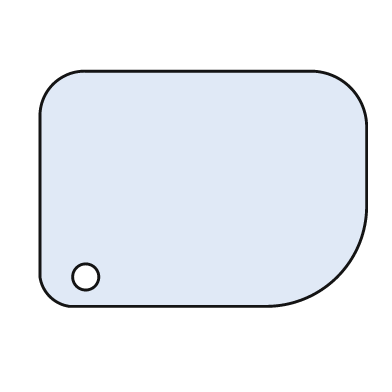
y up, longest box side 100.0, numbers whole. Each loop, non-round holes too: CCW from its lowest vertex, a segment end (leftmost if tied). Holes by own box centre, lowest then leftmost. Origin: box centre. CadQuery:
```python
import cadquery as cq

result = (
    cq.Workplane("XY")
    .moveTo(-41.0, -36.0)
    .lineTo(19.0, -36.0)
    .threePointArc((41.0, -27.0), (50.0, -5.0))
    .lineTo(50.0, 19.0)
    .threePointArc((45.0, 31.0), (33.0, 36.0))
    .lineTo(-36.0, 36.0)
    .threePointArc((-46.0, 32.0), (-50.0, 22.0))
    .lineTo(-50.0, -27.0)
    .threePointArc((-47.0, -33.0), (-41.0, -36.0))
    .close()
    .moveTo(-36.0, -27.0)
    .circle(4.0)
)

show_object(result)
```